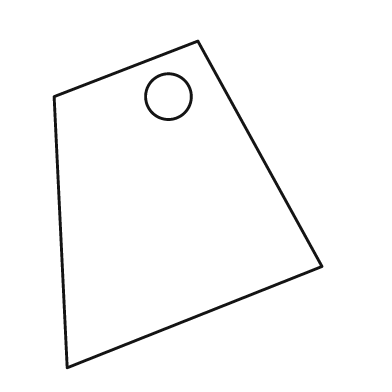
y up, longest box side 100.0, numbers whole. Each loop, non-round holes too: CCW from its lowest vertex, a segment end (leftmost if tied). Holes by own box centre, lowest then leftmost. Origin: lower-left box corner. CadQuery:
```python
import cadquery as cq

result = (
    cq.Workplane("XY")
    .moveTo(4.0, 0.0)
    .lineTo(82.0, 31.0)
    .lineTo(44.0, 100.0)
    .lineTo(0.0, 83.0)
    .close()
    .moveTo(35.0, 83.0)
    .circle(7.0)
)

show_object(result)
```